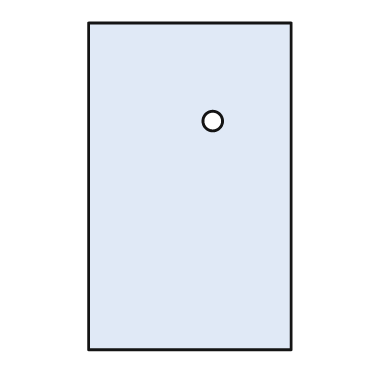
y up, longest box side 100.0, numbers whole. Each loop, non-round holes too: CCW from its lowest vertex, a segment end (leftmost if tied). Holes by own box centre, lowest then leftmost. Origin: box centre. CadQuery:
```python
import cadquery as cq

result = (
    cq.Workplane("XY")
    .moveTo(-31.0, -50.0)
    .lineTo(31.0, -50.0)
    .lineTo(31.0, 50.0)
    .lineTo(-31.0, 50.0)
    .close()
    .moveTo(7.0, 20.0)
    .circle(3.0)
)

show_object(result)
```